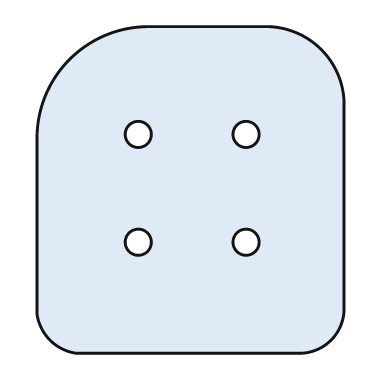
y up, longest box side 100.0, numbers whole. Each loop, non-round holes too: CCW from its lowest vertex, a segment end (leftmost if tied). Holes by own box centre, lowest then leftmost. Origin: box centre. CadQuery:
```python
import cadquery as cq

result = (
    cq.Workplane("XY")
    .moveTo(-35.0, -50.0)
    .lineTo(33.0, -50.0)
    .threePointArc((43.0, -46.0), (47.0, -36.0))
    .lineTo(47.0, 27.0)
    .threePointArc((40.0, 43.0), (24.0, 50.0))
    .lineTo(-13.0, 50.0)
    .threePointArc((-37.0, 40.0), (-47.0, 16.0))
    .lineTo(-47.0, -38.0)
    .threePointArc((-43.0, -46.0), (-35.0, -50.0))
    .close()
    .moveTo(-16.0, -16.0)
    .circle(4.0)
    .moveTo(17.0, -16.0)
    .circle(4.0)
    .moveTo(-16.0, 17.0)
    .circle(4.0)
    .moveTo(17.0, 17.0)
    .circle(4.0)
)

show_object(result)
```